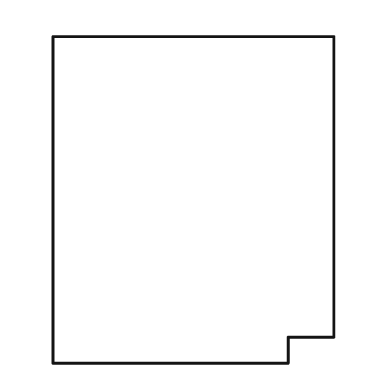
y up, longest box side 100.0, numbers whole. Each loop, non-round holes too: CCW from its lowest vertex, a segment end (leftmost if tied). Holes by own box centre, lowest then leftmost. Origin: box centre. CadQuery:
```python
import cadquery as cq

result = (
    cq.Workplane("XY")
    .moveTo(-43.0, -50.0)
    .lineTo(29.0, -50.0)
    .lineTo(29.0, -42.0)
    .lineTo(43.0, -42.0)
    .lineTo(43.0, 50.0)
    .lineTo(-43.0, 50.0)
    .close()
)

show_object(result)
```